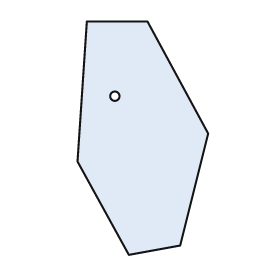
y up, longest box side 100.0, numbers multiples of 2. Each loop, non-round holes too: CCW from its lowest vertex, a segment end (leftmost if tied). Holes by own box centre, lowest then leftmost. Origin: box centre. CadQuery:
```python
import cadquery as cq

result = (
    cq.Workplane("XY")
    .moveTo(-6.0, -50.0)
    .lineTo(16.0, -46.0)
    .lineTo(28.0, 2.0)
    .lineTo(2.0, 50.0)
    .lineTo(-24.0, 50.0)
    .lineTo(-28.0, -10.0)
    .close()
    .moveTo(-12.0, 18.0)
    .circle(2.0)
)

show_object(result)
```